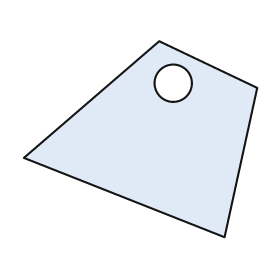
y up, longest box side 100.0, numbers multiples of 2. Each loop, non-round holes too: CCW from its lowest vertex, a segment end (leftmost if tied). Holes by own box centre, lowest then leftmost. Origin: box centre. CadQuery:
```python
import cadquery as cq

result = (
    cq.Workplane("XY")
    .moveTo(36.0, -42.0)
    .lineTo(50.0, 22.0)
    .lineTo(8.0, 42.0)
    .lineTo(-50.0, -8.0)
    .close()
    .moveTo(14.0, 24.0)
    .circle(8.0)
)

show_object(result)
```